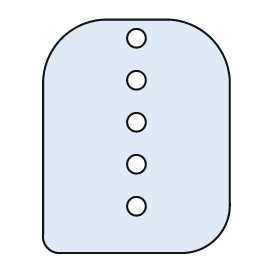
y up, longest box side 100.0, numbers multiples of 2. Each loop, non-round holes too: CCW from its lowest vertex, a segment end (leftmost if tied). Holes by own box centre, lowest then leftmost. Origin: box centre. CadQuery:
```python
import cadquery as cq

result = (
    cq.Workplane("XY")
    .moveTo(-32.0, -50.0)
    .lineTo(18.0, -50.0)
    .threePointArc((34.0, -44.0), (40.0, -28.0))
    .lineTo(40.0, 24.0)
    .threePointArc((32.0, 42.0), (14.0, 50.0))
    .lineTo(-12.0, 50.0)
    .threePointArc((-32.0, 42.0), (-40.0, 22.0))
    .lineTo(-40.0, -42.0)
    .threePointArc((-38.0, -48.0), (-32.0, -50.0))
    .close()
    .moveTo(0.0, -30.0)
    .circle(4.0)
    .moveTo(0.0, -12.0)
    .circle(4.0)
    .moveTo(0.0, 6.0)
    .circle(4.0)
    .moveTo(0.0, 24.0)
    .circle(4.0)
    .moveTo(0.0, 42.0)
    .circle(4.0)
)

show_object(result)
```